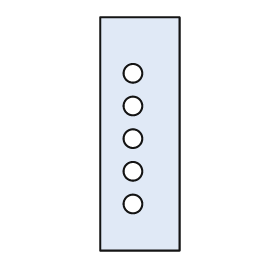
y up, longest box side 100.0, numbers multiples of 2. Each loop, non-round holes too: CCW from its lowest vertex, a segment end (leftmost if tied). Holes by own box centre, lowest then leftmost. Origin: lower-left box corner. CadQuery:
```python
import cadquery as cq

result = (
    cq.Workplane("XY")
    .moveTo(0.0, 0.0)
    .lineTo(34.0, 0.0)
    .lineTo(34.0, 100.0)
    .lineTo(0.0, 100.0)
    .close()
    .moveTo(14.0, 20.0)
    .circle(4.0)
    .moveTo(14.0, 34.0)
    .circle(4.0)
    .moveTo(14.0, 48.0)
    .circle(4.0)
    .moveTo(14.0, 62.0)
    .circle(4.0)
    .moveTo(14.0, 76.0)
    .circle(4.0)
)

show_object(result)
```